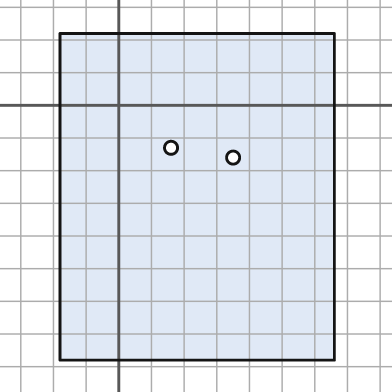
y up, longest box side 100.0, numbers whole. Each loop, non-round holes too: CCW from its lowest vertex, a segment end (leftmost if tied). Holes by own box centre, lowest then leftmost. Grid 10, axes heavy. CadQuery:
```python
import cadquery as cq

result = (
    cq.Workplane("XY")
    .moveTo(-18.0, -78.0)
    .lineTo(66.0, -78.0)
    .lineTo(66.0, 22.0)
    .lineTo(-18.0, 22.0)
    .close()
    .moveTo(35.0, -16.0)
    .circle(2.0)
    .moveTo(16.0, -13.0)
    .circle(2.0)
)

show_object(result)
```